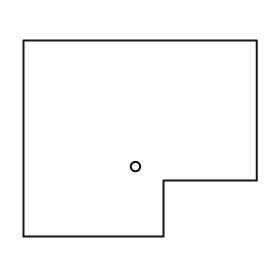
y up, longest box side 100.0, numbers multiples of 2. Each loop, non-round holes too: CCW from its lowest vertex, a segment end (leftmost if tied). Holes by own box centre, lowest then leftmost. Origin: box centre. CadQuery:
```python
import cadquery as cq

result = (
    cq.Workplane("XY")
    .moveTo(-50.0, -42.0)
    .lineTo(10.0, -42.0)
    .lineTo(10.0, -18.0)
    .lineTo(50.0, -18.0)
    .lineTo(50.0, 42.0)
    .lineTo(-50.0, 42.0)
    .close()
    .moveTo(-2.0, -12.0)
    .circle(2.0)
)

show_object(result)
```